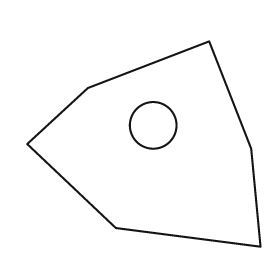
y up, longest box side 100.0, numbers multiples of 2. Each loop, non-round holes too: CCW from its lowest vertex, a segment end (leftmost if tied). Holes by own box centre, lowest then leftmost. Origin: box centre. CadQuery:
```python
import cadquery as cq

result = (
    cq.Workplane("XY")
    .moveTo(50.0, -44.0)
    .lineTo(46.0, -2.0)
    .lineTo(28.0, 44.0)
    .lineTo(-24.0, 24.0)
    .lineTo(-50.0, 0.0)
    .lineTo(-12.0, -36.0)
    .close()
    .moveTo(4.0, 8.0)
    .circle(10.0)
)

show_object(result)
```